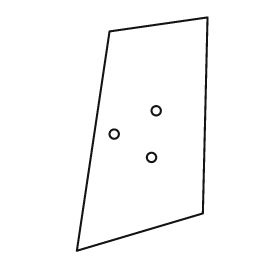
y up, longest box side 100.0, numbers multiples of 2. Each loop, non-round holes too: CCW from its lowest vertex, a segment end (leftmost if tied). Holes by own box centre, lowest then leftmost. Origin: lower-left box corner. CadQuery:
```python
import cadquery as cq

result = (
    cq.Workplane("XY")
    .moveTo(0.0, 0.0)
    .lineTo(54.0, 16.0)
    .lineTo(56.0, 100.0)
    .lineTo(14.0, 94.0)
    .close()
    .moveTo(32.0, 40.0)
    .circle(2.0)
    .moveTo(16.0, 50.0)
    .circle(2.0)
    .moveTo(34.0, 60.0)
    .circle(2.0)
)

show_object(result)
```